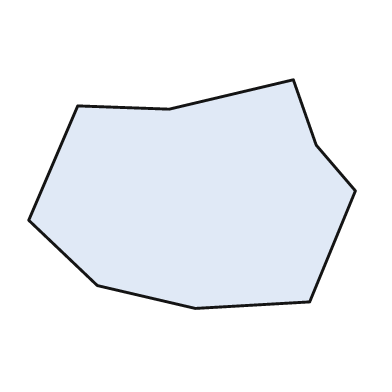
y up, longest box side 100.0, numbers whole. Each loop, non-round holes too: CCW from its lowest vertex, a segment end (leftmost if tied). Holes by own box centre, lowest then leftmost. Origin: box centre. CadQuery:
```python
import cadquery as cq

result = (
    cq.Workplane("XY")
    .moveTo(1.0, -35.0)
    .lineTo(36.0, -33.0)
    .lineTo(50.0, 1.0)
    .lineTo(38.0, 15.0)
    .lineTo(31.0, 35.0)
    .lineTo(-7.0, 26.0)
    .lineTo(-35.0, 27.0)
    .lineTo(-50.0, -8.0)
    .lineTo(-29.0, -28.0)
    .close()
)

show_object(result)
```